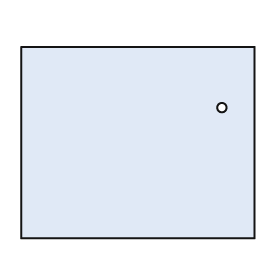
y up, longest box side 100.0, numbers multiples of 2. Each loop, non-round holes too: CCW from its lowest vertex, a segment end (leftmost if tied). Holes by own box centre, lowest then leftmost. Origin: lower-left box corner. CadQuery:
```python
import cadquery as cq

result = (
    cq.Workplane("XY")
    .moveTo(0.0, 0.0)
    .lineTo(100.0, 0.0)
    .lineTo(100.0, 82.0)
    .lineTo(0.0, 82.0)
    .close()
    .moveTo(86.0, 56.0)
    .circle(2.0)
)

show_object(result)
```